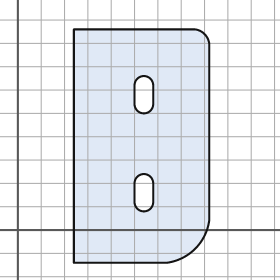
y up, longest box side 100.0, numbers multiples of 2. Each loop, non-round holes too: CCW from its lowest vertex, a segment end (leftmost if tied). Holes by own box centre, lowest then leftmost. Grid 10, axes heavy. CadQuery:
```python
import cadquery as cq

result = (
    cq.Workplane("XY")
    .moveTo(24.0, -14.0)
    .lineTo(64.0, -14.0)
    .threePointArc((76.0, -8.0), (82.0, 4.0))
    .lineTo(82.0, 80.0)
    .threePointArc((80.0, 84.0), (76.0, 86.0))
    .lineTo(24.0, 86.0)
    .close()
    .moveTo(50.0, 12.0)
    .threePointArc((54.0, 8.0), (58.0, 12.0))
    .lineTo(58.0, 20.0)
    .threePointArc((54.0, 24.0), (50.0, 20.0))
    .close()
    .moveTo(50.0, 54.0)
    .threePointArc((54.0, 50.0), (58.0, 54.0))
    .lineTo(58.0, 62.0)
    .threePointArc((54.0, 66.0), (50.0, 62.0))
    .close()
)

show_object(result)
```